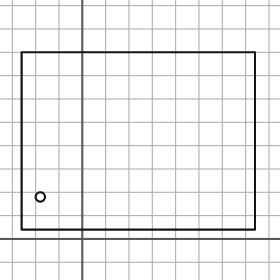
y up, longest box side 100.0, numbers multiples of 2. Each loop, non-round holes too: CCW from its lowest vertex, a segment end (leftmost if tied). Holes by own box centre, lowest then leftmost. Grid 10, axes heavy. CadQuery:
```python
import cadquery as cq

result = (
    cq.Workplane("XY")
    .moveTo(-26.0, 4.0)
    .lineTo(74.0, 4.0)
    .lineTo(74.0, 80.0)
    .lineTo(-26.0, 80.0)
    .close()
    .moveTo(-18.0, 18.0)
    .circle(2.0)
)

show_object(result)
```